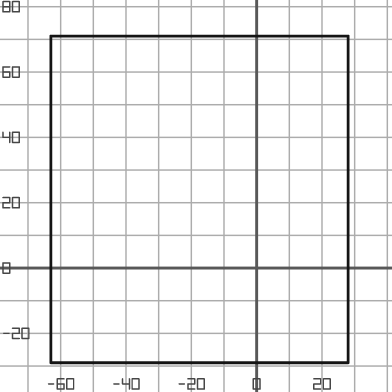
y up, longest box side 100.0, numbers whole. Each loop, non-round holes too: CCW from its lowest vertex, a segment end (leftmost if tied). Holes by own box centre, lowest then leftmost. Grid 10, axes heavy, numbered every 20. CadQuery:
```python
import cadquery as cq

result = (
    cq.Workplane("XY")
    .moveTo(-63.0, -29.0)
    .lineTo(28.0, -29.0)
    .lineTo(28.0, 71.0)
    .lineTo(-63.0, 71.0)
    .close()
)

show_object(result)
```